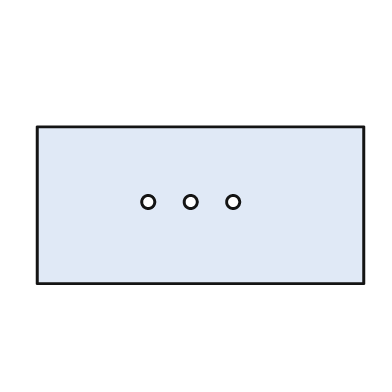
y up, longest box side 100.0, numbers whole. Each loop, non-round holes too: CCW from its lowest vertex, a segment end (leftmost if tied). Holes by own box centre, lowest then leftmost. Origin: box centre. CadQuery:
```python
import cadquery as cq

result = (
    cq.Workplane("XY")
    .moveTo(-50.0, -24.0)
    .lineTo(50.0, -24.0)
    .lineTo(50.0, 24.0)
    .lineTo(-50.0, 24.0)
    .close()
    .moveTo(-16.0, 1.0)
    .circle(2.0)
    .moveTo(-3.0, 1.0)
    .circle(2.0)
    .moveTo(10.0, 1.0)
    .circle(2.0)
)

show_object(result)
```